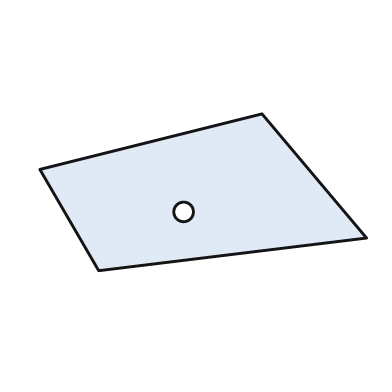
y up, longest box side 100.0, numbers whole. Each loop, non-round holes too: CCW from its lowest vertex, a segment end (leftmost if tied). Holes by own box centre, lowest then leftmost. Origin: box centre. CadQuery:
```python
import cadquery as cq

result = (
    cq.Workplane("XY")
    .moveTo(-32.0, -24.0)
    .lineTo(50.0, -14.0)
    .lineTo(18.0, 24.0)
    .lineTo(-50.0, 7.0)
    .close()
    .moveTo(-6.0, -6.0)
    .circle(3.0)
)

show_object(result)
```